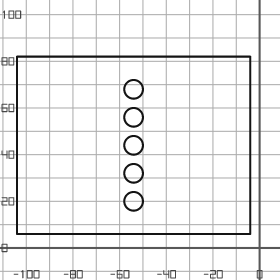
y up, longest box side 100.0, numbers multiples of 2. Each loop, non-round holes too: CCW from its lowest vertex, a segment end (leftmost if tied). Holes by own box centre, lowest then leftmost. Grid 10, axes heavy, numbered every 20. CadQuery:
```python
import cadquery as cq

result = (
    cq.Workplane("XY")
    .moveTo(-104.0, 6.0)
    .lineTo(-4.0, 6.0)
    .lineTo(-4.0, 82.0)
    .lineTo(-104.0, 82.0)
    .close()
    .moveTo(-54.0, 20.0)
    .circle(4.0)
    .moveTo(-54.0, 32.0)
    .circle(4.0)
    .moveTo(-54.0, 44.0)
    .circle(4.0)
    .moveTo(-54.0, 56.0)
    .circle(4.0)
    .moveTo(-54.0, 68.0)
    .circle(4.0)
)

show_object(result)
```